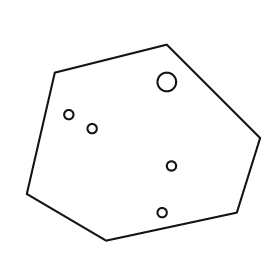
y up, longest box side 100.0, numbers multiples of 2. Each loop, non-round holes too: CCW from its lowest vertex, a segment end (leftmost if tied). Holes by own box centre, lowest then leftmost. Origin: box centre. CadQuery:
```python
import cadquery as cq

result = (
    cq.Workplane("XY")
    .moveTo(-16.0, -42.0)
    .lineTo(40.0, -30.0)
    .lineTo(50.0, 2.0)
    .lineTo(10.0, 42.0)
    .lineTo(-38.0, 30.0)
    .lineTo(-50.0, -22.0)
    .close()
    .moveTo(8.0, -30.0)
    .circle(2.0)
    .moveTo(12.0, -10.0)
    .circle(2.0)
    .moveTo(-22.0, 6.0)
    .circle(2.0)
    .moveTo(-32.0, 12.0)
    .circle(2.0)
    .moveTo(10.0, 26.0)
    .circle(4.0)
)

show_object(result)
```